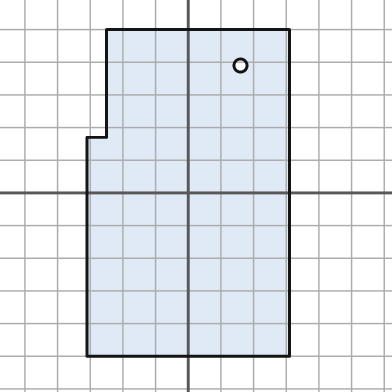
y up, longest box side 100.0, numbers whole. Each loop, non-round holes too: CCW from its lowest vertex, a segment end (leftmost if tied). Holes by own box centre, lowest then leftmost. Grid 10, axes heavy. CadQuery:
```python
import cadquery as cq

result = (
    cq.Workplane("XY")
    .moveTo(-31.0, -50.0)
    .lineTo(31.0, -50.0)
    .lineTo(31.0, 50.0)
    .lineTo(-25.0, 50.0)
    .lineTo(-25.0, 17.0)
    .lineTo(-31.0, 17.0)
    .close()
    .moveTo(16.0, 39.0)
    .circle(2.0)
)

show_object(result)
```